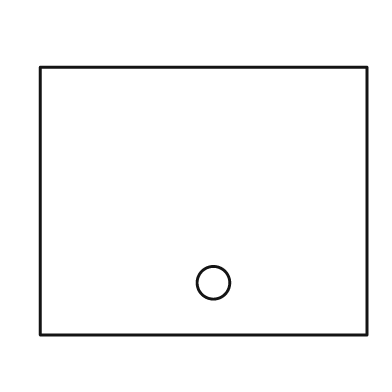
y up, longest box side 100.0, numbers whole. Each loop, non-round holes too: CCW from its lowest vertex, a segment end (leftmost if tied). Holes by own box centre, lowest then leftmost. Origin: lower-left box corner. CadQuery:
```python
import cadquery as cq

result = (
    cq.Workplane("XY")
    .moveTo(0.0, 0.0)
    .lineTo(100.0, 0.0)
    .lineTo(100.0, 82.0)
    .lineTo(0.0, 82.0)
    .close()
    .moveTo(53.0, 16.0)
    .circle(5.0)
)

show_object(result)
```